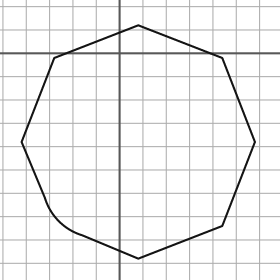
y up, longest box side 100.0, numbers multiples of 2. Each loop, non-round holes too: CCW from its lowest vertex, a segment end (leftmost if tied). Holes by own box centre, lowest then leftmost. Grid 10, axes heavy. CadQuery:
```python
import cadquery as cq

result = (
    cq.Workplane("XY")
    .moveTo(8.0, -88.0)
    .lineTo(44.0, -74.0)
    .lineTo(58.0, -38.0)
    .lineTo(44.0, -2.0)
    .lineTo(8.0, 12.0)
    .lineTo(-28.0, -2.0)
    .lineTo(-42.0, -38.0)
    .lineTo(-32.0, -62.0)
    .threePointArc((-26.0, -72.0), (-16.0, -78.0))
    .close()
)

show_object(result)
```